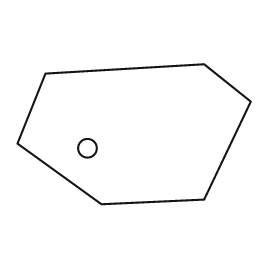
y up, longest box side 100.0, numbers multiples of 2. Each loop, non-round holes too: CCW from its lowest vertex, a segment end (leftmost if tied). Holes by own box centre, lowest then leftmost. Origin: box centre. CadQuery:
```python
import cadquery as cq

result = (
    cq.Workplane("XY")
    .moveTo(-14.0, -30.0)
    .lineTo(30.0, -28.0)
    .lineTo(50.0, 14.0)
    .lineTo(30.0, 30.0)
    .lineTo(-38.0, 26.0)
    .lineTo(-50.0, -4.0)
    .close()
    .moveTo(-20.0, -6.0)
    .circle(4.0)
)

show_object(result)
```